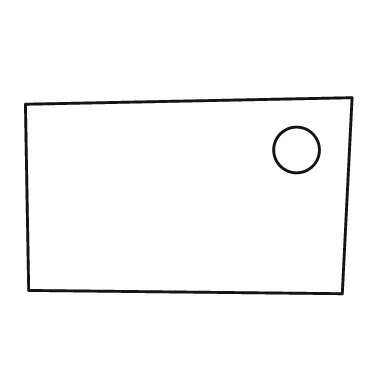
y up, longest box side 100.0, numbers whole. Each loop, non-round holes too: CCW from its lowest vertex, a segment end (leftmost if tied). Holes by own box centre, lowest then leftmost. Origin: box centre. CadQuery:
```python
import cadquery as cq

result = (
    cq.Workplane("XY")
    .moveTo(47.0, -30.0)
    .lineTo(50.0, 30.0)
    .lineTo(-50.0, 28.0)
    .lineTo(-49.0, -29.0)
    .close()
    .moveTo(33.0, 14.0)
    .circle(7.0)
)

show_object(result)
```